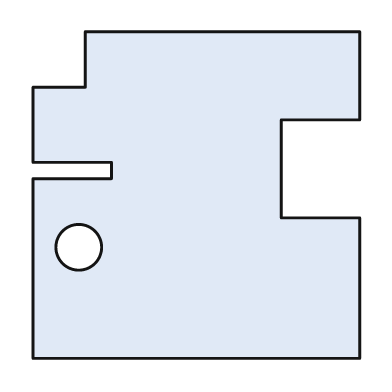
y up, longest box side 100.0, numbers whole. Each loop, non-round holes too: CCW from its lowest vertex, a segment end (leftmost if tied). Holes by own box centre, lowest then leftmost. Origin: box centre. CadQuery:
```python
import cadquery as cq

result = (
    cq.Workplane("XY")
    .moveTo(-50.0, -50.0)
    .lineTo(50.0, -50.0)
    .lineTo(50.0, -7.0)
    .lineTo(26.0, -7.0)
    .lineTo(26.0, 23.0)
    .lineTo(50.0, 23.0)
    .lineTo(50.0, 50.0)
    .lineTo(-34.0, 50.0)
    .lineTo(-34.0, 33.0)
    .lineTo(-50.0, 33.0)
    .lineTo(-50.0, 10.0)
    .lineTo(-26.0, 10.0)
    .lineTo(-26.0, 5.0)
    .lineTo(-50.0, 5.0)
    .close()
    .moveTo(-36.0, -16.0)
    .circle(7.0)
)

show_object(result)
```